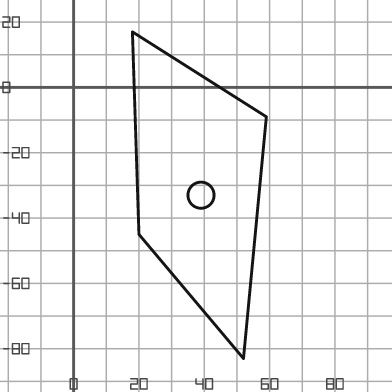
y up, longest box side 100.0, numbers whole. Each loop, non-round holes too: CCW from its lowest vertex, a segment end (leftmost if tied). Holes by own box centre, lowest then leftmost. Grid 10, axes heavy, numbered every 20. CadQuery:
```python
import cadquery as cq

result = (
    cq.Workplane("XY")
    .moveTo(52.0, -83.0)
    .lineTo(59.0, -9.0)
    .lineTo(18.0, 17.0)
    .lineTo(20.0, -45.0)
    .close()
    .moveTo(39.0, -33.0)
    .circle(4.0)
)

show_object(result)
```